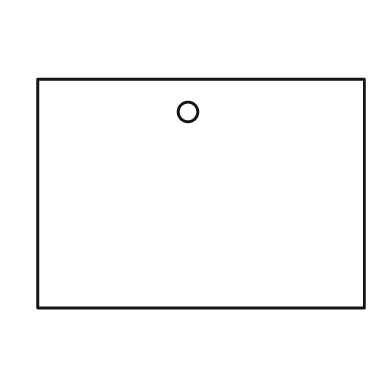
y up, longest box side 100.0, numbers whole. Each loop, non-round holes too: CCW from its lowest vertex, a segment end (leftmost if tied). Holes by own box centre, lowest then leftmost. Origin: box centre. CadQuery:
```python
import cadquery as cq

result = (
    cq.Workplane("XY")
    .moveTo(-50.0, -35.0)
    .lineTo(50.0, -35.0)
    .lineTo(50.0, 35.0)
    .lineTo(-50.0, 35.0)
    .close()
    .moveTo(-4.0, 25.0)
    .circle(3.0)
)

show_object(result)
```